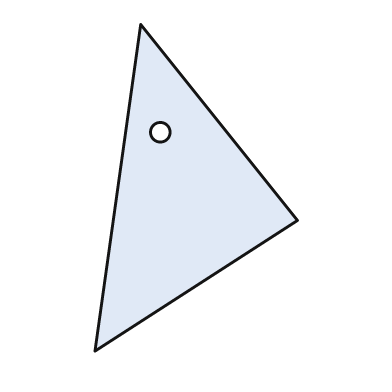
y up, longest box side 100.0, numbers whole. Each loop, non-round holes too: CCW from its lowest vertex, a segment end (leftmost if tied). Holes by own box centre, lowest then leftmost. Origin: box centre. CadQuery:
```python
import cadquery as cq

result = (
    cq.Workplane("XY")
    .moveTo(-31.0, -50.0)
    .lineTo(31.0, -10.0)
    .lineTo(-17.0, 50.0)
    .close()
    .moveTo(-11.0, 17.0)
    .circle(3.0)
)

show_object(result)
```